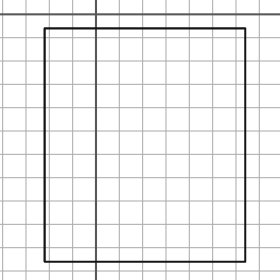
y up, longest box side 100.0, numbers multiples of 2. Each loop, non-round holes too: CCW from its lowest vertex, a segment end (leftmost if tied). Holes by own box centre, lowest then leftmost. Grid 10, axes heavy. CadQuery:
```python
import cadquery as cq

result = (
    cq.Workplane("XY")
    .moveTo(-22.0, -106.0)
    .lineTo(64.0, -106.0)
    .lineTo(64.0, -6.0)
    .lineTo(-22.0, -6.0)
    .close()
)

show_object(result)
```